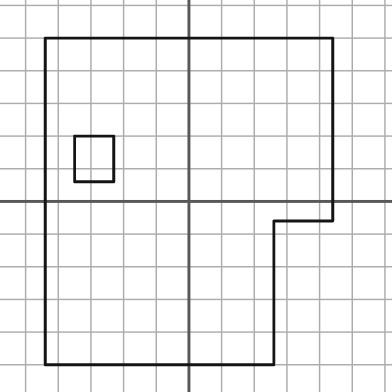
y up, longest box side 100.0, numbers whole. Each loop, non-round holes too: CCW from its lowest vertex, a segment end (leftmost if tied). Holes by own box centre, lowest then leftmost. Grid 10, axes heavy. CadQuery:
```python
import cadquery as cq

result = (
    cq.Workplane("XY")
    .moveTo(-44.0, -50.0)
    .lineTo(26.0, -50.0)
    .lineTo(26.0, -6.0)
    .lineTo(44.0, -6.0)
    .lineTo(44.0, 50.0)
    .lineTo(-44.0, 50.0)
    .close()
    .moveTo(-35.0, 6.0)
    .lineTo(-23.0, 6.0)
    .lineTo(-23.0, 20.0)
    .lineTo(-35.0, 20.0)
    .close()
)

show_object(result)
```